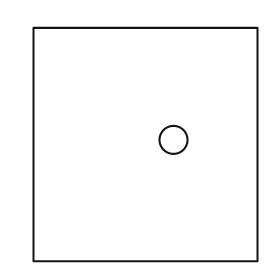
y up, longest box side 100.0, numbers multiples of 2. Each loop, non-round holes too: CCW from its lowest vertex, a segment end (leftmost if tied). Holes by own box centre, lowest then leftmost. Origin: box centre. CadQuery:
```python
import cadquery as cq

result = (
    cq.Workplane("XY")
    .moveTo(-48.0, -50.0)
    .lineTo(48.0, -50.0)
    .lineTo(48.0, 50.0)
    .lineTo(-48.0, 50.0)
    .close()
    .moveTo(12.0, 2.0)
    .circle(6.0)
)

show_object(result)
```